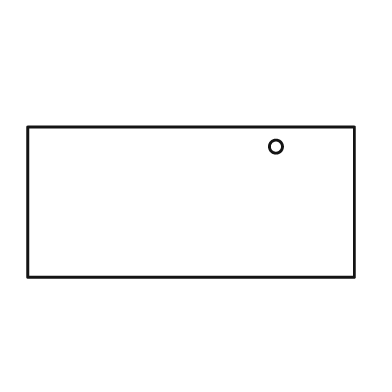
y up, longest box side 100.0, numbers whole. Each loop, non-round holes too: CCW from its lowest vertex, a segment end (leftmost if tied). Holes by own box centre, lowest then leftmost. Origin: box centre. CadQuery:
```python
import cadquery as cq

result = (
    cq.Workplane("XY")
    .moveTo(-50.0, -23.0)
    .lineTo(50.0, -23.0)
    .lineTo(50.0, 23.0)
    .lineTo(-50.0, 23.0)
    .close()
    .moveTo(26.0, 17.0)
    .circle(2.0)
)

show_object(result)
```